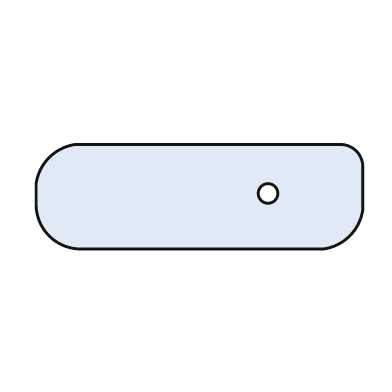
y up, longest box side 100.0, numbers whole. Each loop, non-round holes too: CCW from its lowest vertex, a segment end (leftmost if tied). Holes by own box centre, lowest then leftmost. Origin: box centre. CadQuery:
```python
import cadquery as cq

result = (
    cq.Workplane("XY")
    .moveTo(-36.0, -16.0)
    .lineTo(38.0, -16.0)
    .threePointArc((46.0, -12.0), (50.0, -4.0))
    .lineTo(50.0, 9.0)
    .threePointArc((48.0, 14.0), (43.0, 16.0))
    .lineTo(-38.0, 16.0)
    .threePointArc((-46.0, 12.0), (-50.0, 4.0))
    .lineTo(-50.0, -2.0)
    .threePointArc((-46.0, -12.0), (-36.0, -16.0))
    .close()
    .moveTo(21.0, 1.0)
    .circle(3.0)
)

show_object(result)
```